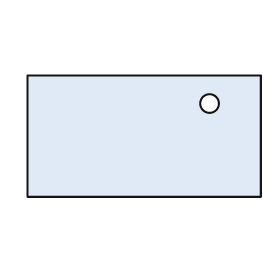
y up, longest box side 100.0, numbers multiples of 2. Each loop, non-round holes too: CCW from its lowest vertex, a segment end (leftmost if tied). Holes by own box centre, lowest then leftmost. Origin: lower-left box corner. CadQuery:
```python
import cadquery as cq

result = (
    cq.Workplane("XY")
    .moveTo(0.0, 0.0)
    .lineTo(100.0, 0.0)
    .lineTo(100.0, 52.0)
    .lineTo(0.0, 52.0)
    .close()
    .moveTo(78.0, 40.0)
    .circle(4.0)
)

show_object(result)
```